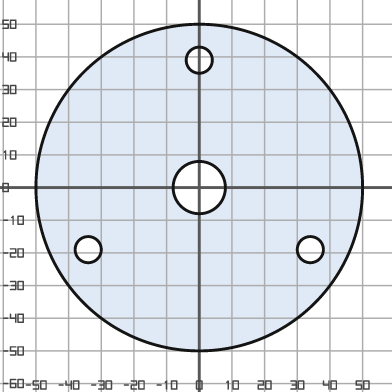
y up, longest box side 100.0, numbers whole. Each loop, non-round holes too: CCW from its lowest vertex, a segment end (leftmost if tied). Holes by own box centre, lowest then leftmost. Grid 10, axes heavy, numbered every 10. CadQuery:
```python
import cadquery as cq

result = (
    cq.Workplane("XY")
    .moveTo(0.0, 0.0)
    .circle(50.0)
    .moveTo(-34.0, -19.0)
    .circle(4.0)
    .moveTo(34.0, -19.0)
    .circle(4.0)
    .moveTo(0.0, 0.0)
    .circle(8.0)
    .moveTo(0.0, 39.0)
    .circle(4.0)
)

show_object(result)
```